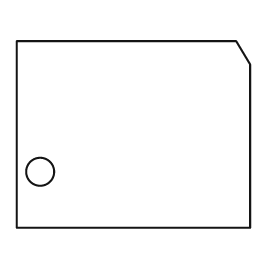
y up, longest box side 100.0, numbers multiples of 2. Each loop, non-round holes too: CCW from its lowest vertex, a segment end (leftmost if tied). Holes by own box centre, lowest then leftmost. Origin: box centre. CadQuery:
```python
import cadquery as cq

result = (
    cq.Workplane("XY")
    .moveTo(-50.0, -40.0)
    .lineTo(50.0, -40.0)
    .lineTo(50.0, 30.0)
    .lineTo(44.0, 40.0)
    .lineTo(-50.0, 40.0)
    .close()
    .moveTo(-40.0, -16.0)
    .circle(6.0)
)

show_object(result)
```